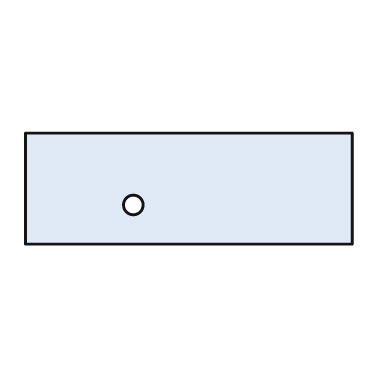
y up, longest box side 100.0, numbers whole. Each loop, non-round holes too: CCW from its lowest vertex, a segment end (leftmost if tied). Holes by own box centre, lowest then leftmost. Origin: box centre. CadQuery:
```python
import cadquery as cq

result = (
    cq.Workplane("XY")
    .moveTo(-50.0, -17.0)
    .lineTo(50.0, -17.0)
    .lineTo(50.0, 17.0)
    .lineTo(-50.0, 17.0)
    .close()
    .moveTo(-17.0, -5.0)
    .circle(3.0)
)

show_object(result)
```